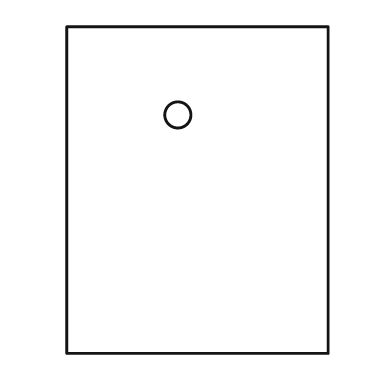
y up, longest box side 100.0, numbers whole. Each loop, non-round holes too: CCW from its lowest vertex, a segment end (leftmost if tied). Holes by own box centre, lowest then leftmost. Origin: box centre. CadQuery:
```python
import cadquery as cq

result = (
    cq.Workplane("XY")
    .moveTo(-40.0, -50.0)
    .lineTo(40.0, -50.0)
    .lineTo(40.0, 50.0)
    .lineTo(-40.0, 50.0)
    .close()
    .moveTo(-6.0, 23.0)
    .circle(4.0)
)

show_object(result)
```